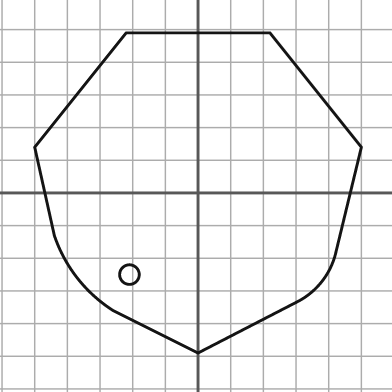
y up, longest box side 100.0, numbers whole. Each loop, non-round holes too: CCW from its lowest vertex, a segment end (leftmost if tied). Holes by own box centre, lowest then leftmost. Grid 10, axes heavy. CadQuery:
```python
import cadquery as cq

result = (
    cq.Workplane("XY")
    .moveTo(0.0, -49.0)
    .lineTo(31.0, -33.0)
    .threePointArc((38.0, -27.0), (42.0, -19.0))
    .lineTo(50.0, 14.0)
    .lineTo(22.0, 49.0)
    .lineTo(-22.0, 49.0)
    .lineTo(-50.0, 14.0)
    .lineTo(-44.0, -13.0)
    .threePointArc((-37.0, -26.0), (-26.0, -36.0))
    .close()
    .moveTo(-21.0, -25.0)
    .circle(3.0)
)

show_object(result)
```